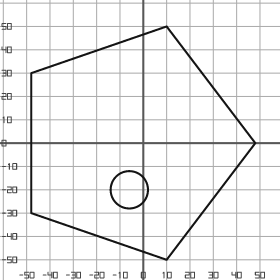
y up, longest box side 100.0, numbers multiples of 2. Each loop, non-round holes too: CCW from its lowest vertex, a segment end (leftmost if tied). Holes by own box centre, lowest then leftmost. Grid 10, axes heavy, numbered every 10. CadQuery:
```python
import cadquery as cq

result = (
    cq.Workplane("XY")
    .moveTo(10.0, -50.0)
    .lineTo(48.0, 0.0)
    .lineTo(10.0, 50.0)
    .lineTo(-48.0, 30.0)
    .lineTo(-48.0, -30.0)
    .close()
    .moveTo(-6.0, -20.0)
    .circle(8.0)
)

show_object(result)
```